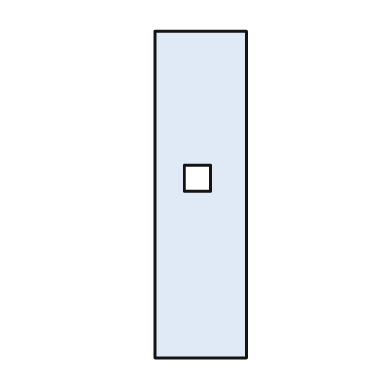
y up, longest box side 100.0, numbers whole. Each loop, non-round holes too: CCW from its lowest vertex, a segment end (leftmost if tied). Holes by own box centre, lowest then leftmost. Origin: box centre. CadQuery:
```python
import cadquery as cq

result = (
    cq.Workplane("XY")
    .moveTo(-14.0, -50.0)
    .lineTo(14.0, -50.0)
    .lineTo(14.0, 50.0)
    .lineTo(-14.0, 50.0)
    .close()
    .moveTo(-5.0, 1.0)
    .lineTo(3.0, 1.0)
    .lineTo(3.0, 9.0)
    .lineTo(-5.0, 9.0)
    .close()
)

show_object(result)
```